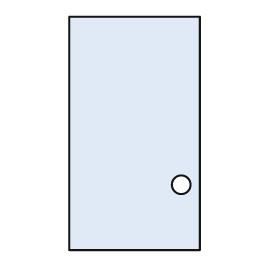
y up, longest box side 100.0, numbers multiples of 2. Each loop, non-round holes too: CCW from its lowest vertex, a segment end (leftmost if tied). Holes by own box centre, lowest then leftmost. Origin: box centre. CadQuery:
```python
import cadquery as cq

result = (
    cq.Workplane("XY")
    .moveTo(-28.0, -50.0)
    .lineTo(28.0, -50.0)
    .lineTo(28.0, 50.0)
    .lineTo(-28.0, 50.0)
    .close()
    .moveTo(20.0, -22.0)
    .circle(4.0)
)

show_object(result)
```